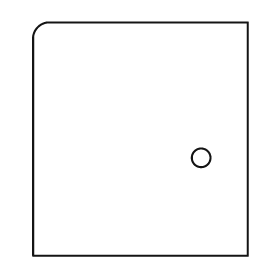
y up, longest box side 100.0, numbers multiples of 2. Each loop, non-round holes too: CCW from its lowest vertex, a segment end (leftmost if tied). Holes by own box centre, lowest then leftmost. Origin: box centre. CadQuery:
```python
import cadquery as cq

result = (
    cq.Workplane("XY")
    .moveTo(-46.0, -50.0)
    .lineTo(46.0, -50.0)
    .lineTo(46.0, 50.0)
    .lineTo(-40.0, 50.0)
    .threePointArc((-44.0, 48.0), (-46.0, 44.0))
    .close()
    .moveTo(26.0, -8.0)
    .circle(4.0)
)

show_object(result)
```